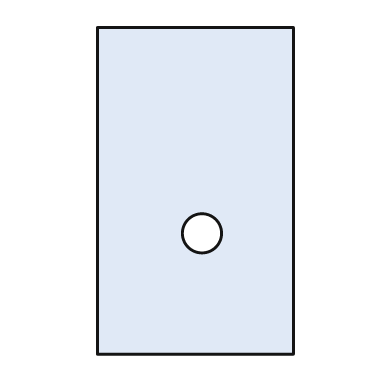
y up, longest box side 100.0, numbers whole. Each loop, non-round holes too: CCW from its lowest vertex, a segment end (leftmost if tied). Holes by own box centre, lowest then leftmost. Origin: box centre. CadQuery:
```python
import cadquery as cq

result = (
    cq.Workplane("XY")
    .moveTo(-30.0, -50.0)
    .lineTo(30.0, -50.0)
    .lineTo(30.0, 50.0)
    .lineTo(-30.0, 50.0)
    .close()
    .moveTo(2.0, -13.0)
    .circle(6.0)
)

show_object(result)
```